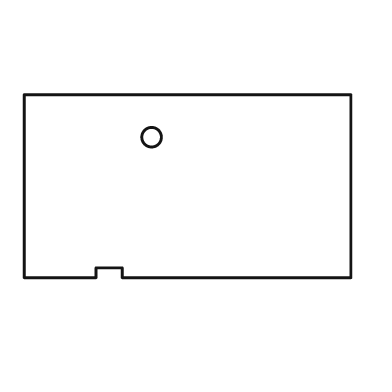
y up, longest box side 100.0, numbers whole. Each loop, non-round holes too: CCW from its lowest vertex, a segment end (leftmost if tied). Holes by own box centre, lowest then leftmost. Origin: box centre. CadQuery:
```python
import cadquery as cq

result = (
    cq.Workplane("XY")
    .moveTo(-50.0, -28.0)
    .lineTo(-28.0, -28.0)
    .lineTo(-28.0, -25.0)
    .lineTo(-20.0, -25.0)
    .lineTo(-20.0, -28.0)
    .lineTo(50.0, -28.0)
    .lineTo(50.0, 28.0)
    .lineTo(-50.0, 28.0)
    .close()
    .moveTo(-11.0, 15.0)
    .circle(3.0)
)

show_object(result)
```